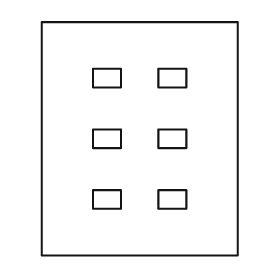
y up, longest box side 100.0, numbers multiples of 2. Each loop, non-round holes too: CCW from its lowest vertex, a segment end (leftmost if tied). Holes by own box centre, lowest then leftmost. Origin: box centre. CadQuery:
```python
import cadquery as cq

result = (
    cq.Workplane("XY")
    .moveTo(-42.0, -50.0)
    .lineTo(42.0, -50.0)
    .lineTo(42.0, 50.0)
    .lineTo(-42.0, 50.0)
    .close()
    .moveTo(-20.0, -30.0)
    .lineTo(-8.0, -30.0)
    .lineTo(-8.0, -22.0)
    .lineTo(-20.0, -22.0)
    .close()
    .moveTo(8.0, -30.0)
    .lineTo(20.0, -30.0)
    .lineTo(20.0, -22.0)
    .lineTo(8.0, -22.0)
    .close()
    .moveTo(-20.0, -4.0)
    .lineTo(-8.0, -4.0)
    .lineTo(-8.0, 4.0)
    .lineTo(-20.0, 4.0)
    .close()
    .moveTo(8.0, -4.0)
    .lineTo(20.0, -4.0)
    .lineTo(20.0, 4.0)
    .lineTo(8.0, 4.0)
    .close()
    .moveTo(-20.0, 22.0)
    .lineTo(-8.0, 22.0)
    .lineTo(-8.0, 30.0)
    .lineTo(-20.0, 30.0)
    .close()
    .moveTo(8.0, 22.0)
    .lineTo(20.0, 22.0)
    .lineTo(20.0, 30.0)
    .lineTo(8.0, 30.0)
    .close()
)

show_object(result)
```